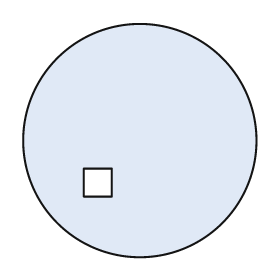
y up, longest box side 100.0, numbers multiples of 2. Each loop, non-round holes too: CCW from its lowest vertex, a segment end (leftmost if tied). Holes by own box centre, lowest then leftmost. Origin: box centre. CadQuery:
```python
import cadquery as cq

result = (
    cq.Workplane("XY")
    .moveTo(0.0, 0.0)
    .circle(50.0)
    .moveTo(-24.0, -24.0)
    .lineTo(-12.0, -24.0)
    .lineTo(-12.0, -12.0)
    .lineTo(-24.0, -12.0)
    .close()
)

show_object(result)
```